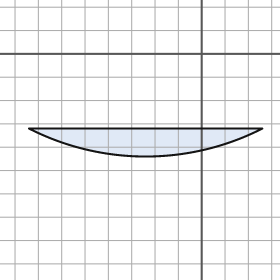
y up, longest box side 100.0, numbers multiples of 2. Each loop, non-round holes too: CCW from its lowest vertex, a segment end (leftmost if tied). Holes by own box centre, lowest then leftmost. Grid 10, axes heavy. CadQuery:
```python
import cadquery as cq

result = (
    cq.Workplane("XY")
    .moveTo(-74.0, -32.0)
    .threePointArc((-24.0, -44.0), (26.0, -32.0))
    .close()
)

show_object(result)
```